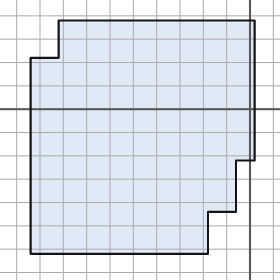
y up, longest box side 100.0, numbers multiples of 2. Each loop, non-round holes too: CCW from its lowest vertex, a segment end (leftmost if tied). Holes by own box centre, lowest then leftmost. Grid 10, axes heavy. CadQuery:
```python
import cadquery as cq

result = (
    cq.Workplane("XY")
    .moveTo(-94.0, -62.0)
    .lineTo(-18.0, -62.0)
    .lineTo(-18.0, -44.0)
    .lineTo(-6.0, -44.0)
    .lineTo(-6.0, -22.0)
    .lineTo(2.0, -22.0)
    .lineTo(2.0, 38.0)
    .lineTo(-82.0, 38.0)
    .lineTo(-82.0, 22.0)
    .lineTo(-94.0, 22.0)
    .close()
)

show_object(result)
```